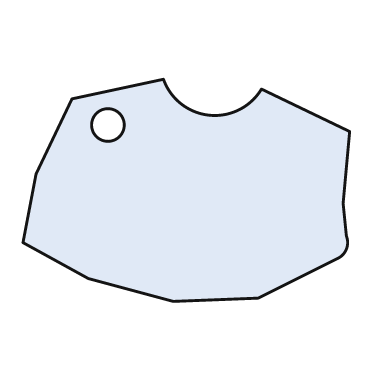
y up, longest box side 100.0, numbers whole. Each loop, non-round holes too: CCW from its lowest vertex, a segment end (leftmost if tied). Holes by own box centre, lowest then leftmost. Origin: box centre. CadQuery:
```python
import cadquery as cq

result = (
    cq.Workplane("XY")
    .moveTo(-4.0, -34.0)
    .lineTo(22.0, -33.0)
    .lineTo(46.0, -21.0)
    .threePointArc((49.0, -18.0), (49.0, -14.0))
    .lineTo(48.0, -4.0)
    .lineTo(50.0, 18.0)
    .lineTo(23.0, 31.0)
    .threePointArc((7.0, 23.0), (-7.0, 34.0))
    .lineTo(-35.0, 28.0)
    .lineTo(-46.0, 5.0)
    .lineTo(-50.0, -16.0)
    .lineTo(-30.0, -27.0)
    .close()
    .moveTo(-24.0, 20.0)
    .circle(5.0)
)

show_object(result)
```